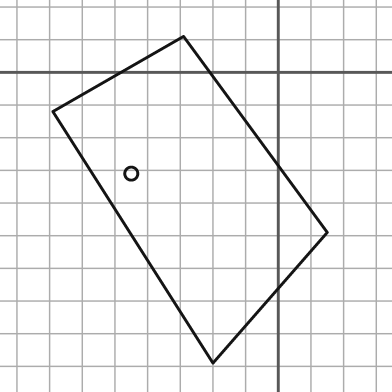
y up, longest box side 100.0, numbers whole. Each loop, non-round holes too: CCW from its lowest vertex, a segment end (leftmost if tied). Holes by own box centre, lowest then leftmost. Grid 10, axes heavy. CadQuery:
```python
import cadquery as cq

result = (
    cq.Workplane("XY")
    .moveTo(-20.0, -89.0)
    .lineTo(15.0, -49.0)
    .lineTo(-29.0, 11.0)
    .lineTo(-69.0, -12.0)
    .close()
    .moveTo(-45.0, -31.0)
    .circle(2.0)
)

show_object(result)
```